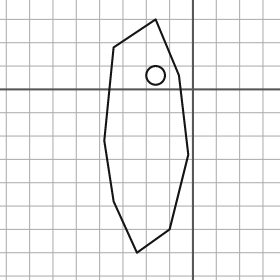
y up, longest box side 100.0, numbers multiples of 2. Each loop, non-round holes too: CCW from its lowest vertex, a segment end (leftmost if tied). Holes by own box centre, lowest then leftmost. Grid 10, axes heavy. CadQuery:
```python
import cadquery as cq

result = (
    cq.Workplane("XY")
    .moveTo(-24.0, -70.0)
    .lineTo(-10.0, -60.0)
    .lineTo(-2.0, -28.0)
    .lineTo(-6.0, 6.0)
    .lineTo(-16.0, 30.0)
    .lineTo(-34.0, 18.0)
    .lineTo(-38.0, -22.0)
    .lineTo(-34.0, -48.0)
    .close()
    .moveTo(-16.0, 6.0)
    .circle(4.0)
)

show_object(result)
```